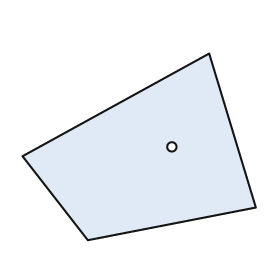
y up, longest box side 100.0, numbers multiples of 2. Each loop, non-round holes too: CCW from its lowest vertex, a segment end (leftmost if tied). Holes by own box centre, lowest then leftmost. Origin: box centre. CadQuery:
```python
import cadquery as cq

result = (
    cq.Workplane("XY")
    .moveTo(-22.0, -40.0)
    .lineTo(50.0, -26.0)
    .lineTo(30.0, 40.0)
    .lineTo(-50.0, -4.0)
    .close()
    .moveTo(14.0, 0.0)
    .circle(2.0)
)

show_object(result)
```